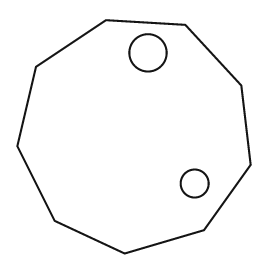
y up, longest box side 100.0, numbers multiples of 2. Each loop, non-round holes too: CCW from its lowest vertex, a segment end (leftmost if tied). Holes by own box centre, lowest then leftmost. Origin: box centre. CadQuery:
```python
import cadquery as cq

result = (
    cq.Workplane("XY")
    .moveTo(-4.0, -50.0)
    .lineTo(30.0, -40.0)
    .lineTo(50.0, -12.0)
    .lineTo(46.0, 22.0)
    .lineTo(22.0, 48.0)
    .lineTo(-12.0, 50.0)
    .lineTo(-42.0, 30.0)
    .lineTo(-50.0, -4.0)
    .lineTo(-34.0, -36.0)
    .close()
    .moveTo(26.0, -20.0)
    .circle(6.0)
    .moveTo(6.0, 36.0)
    .circle(8.0)
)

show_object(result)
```